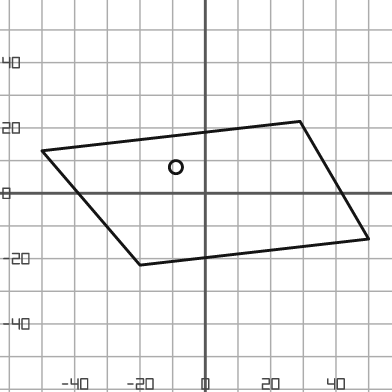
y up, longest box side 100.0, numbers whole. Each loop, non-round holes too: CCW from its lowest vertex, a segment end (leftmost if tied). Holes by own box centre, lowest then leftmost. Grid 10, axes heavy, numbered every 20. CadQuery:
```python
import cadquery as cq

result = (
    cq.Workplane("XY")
    .moveTo(-20.0, -22.0)
    .lineTo(50.0, -14.0)
    .lineTo(29.0, 22.0)
    .lineTo(-50.0, 13.0)
    .close()
    .moveTo(-9.0, 8.0)
    .circle(2.0)
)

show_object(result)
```